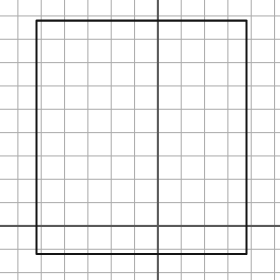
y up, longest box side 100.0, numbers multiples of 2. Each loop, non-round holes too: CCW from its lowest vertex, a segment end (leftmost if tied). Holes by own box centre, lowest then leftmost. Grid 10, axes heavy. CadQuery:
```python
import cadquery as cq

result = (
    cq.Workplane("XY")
    .moveTo(-52.0, -12.0)
    .lineTo(38.0, -12.0)
    .lineTo(38.0, 88.0)
    .lineTo(-52.0, 88.0)
    .close()
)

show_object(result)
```